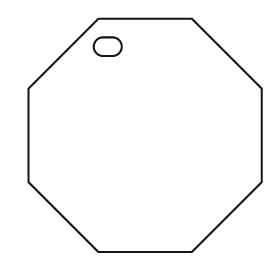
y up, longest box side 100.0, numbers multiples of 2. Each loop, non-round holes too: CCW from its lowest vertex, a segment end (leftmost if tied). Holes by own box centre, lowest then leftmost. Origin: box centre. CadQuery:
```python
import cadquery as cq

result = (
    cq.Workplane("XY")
    .moveTo(-20.0, -50.0)
    .lineTo(20.0, -50.0)
    .lineTo(50.0, -20.0)
    .lineTo(50.0, 20.0)
    .lineTo(20.0, 50.0)
    .lineTo(-20.0, 50.0)
    .lineTo(-50.0, 20.0)
    .lineTo(-50.0, -20.0)
    .close()
    .moveTo(-18.0, 34.0)
    .lineTo(-14.0, 34.0)
    .threePointArc((-10.0, 38.0), (-14.0, 42.0))
    .lineTo(-18.0, 42.0)
    .threePointArc((-22.0, 38.0), (-18.0, 34.0))
    .close()
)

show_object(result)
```